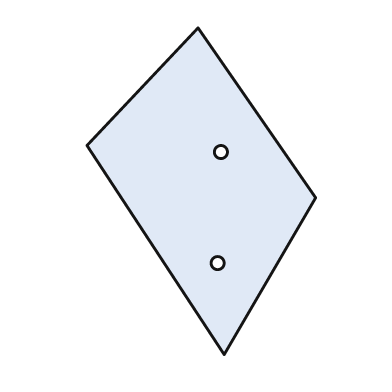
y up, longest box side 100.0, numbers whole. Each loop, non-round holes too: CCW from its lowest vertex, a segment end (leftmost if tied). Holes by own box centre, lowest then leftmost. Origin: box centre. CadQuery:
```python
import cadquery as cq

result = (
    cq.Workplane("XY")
    .moveTo(7.0, -50.0)
    .lineTo(35.0, -2.0)
    .lineTo(-1.0, 50.0)
    .lineTo(-35.0, 14.0)
    .close()
    .moveTo(5.0, -22.0)
    .circle(2.0)
    .moveTo(6.0, 12.0)
    .circle(2.0)
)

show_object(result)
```